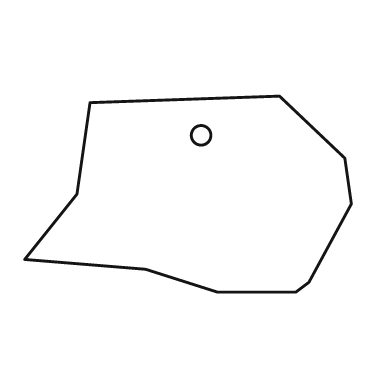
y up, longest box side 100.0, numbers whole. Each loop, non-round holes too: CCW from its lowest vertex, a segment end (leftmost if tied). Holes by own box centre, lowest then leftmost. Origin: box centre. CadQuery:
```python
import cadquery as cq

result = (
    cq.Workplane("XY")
    .moveTo(9.0, -30.0)
    .lineTo(33.0, -30.0)
    .lineTo(37.0, -27.0)
    .lineTo(50.0, -3.0)
    .lineTo(48.0, 11.0)
    .lineTo(28.0, 30.0)
    .lineTo(-30.0, 28.0)
    .lineTo(-34.0, 0.0)
    .lineTo(-50.0, -20.0)
    .lineTo(-13.0, -23.0)
    .close()
    .moveTo(4.0, 18.0)
    .circle(3.0)
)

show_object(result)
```